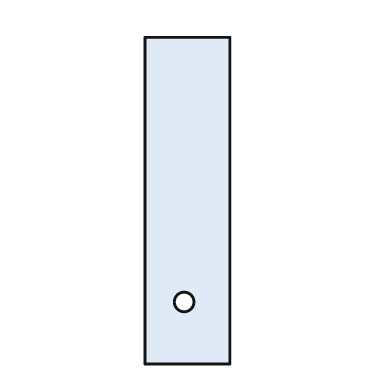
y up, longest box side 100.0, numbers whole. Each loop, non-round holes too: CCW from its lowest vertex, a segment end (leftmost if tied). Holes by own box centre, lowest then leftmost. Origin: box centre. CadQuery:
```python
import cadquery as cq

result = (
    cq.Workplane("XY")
    .moveTo(-13.0, -50.0)
    .lineTo(13.0, -50.0)
    .lineTo(13.0, 50.0)
    .lineTo(-13.0, 50.0)
    .close()
    .moveTo(-1.0, -31.0)
    .circle(3.0)
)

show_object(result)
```